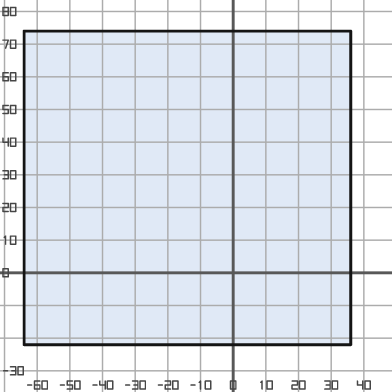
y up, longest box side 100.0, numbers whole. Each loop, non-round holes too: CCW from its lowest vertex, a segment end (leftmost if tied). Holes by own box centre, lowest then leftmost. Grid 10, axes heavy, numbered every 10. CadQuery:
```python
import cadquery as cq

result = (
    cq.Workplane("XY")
    .moveTo(-64.0, -22.0)
    .lineTo(36.0, -22.0)
    .lineTo(36.0, 74.0)
    .lineTo(-64.0, 74.0)
    .close()
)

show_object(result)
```